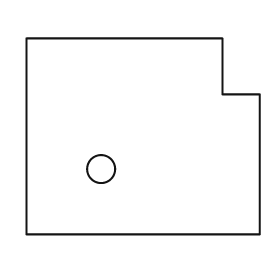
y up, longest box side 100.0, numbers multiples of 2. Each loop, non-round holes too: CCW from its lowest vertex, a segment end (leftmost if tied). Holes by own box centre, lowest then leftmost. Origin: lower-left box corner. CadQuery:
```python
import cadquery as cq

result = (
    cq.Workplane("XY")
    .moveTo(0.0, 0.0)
    .lineTo(100.0, 0.0)
    .lineTo(100.0, 60.0)
    .lineTo(84.0, 60.0)
    .lineTo(84.0, 84.0)
    .lineTo(0.0, 84.0)
    .close()
    .moveTo(32.0, 28.0)
    .circle(6.0)
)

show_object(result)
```